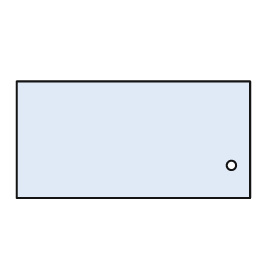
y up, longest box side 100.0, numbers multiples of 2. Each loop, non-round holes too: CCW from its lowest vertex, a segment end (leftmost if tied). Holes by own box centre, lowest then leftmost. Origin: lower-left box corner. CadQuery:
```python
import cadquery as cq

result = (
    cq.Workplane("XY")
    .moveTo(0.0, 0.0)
    .lineTo(100.0, 0.0)
    .lineTo(100.0, 50.0)
    .lineTo(0.0, 50.0)
    .close()
    .moveTo(92.0, 14.0)
    .circle(2.0)
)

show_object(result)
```